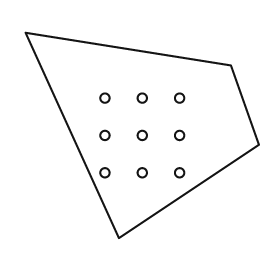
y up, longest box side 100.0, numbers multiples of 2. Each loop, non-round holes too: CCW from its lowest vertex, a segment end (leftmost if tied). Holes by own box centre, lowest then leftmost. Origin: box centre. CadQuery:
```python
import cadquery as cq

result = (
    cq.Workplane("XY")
    .moveTo(-10.0, -44.0)
    .lineTo(50.0, -4.0)
    .lineTo(38.0, 30.0)
    .lineTo(-50.0, 44.0)
    .close()
    .moveTo(-16.0, -16.0)
    .circle(2.0)
    .moveTo(0.0, -16.0)
    .circle(2.0)
    .moveTo(16.0, -16.0)
    .circle(2.0)
    .moveTo(-16.0, 0.0)
    .circle(2.0)
    .moveTo(0.0, 0.0)
    .circle(2.0)
    .moveTo(16.0, 0.0)
    .circle(2.0)
    .moveTo(-16.0, 16.0)
    .circle(2.0)
    .moveTo(0.0, 16.0)
    .circle(2.0)
    .moveTo(16.0, 16.0)
    .circle(2.0)
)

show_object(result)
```